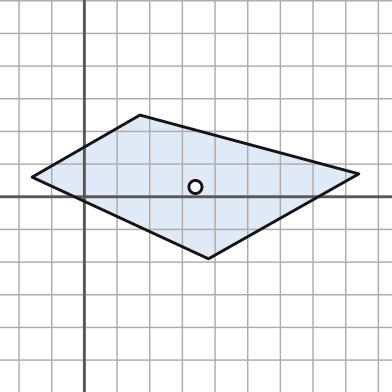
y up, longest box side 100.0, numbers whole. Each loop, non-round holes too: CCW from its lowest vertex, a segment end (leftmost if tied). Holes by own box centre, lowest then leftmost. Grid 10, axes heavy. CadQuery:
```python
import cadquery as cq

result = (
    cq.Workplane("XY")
    .moveTo(38.0, -19.0)
    .lineTo(84.0, 7.0)
    .lineTo(17.0, 25.0)
    .lineTo(-16.0, 6.0)
    .close()
    .moveTo(34.0, 3.0)
    .circle(2.0)
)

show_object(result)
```